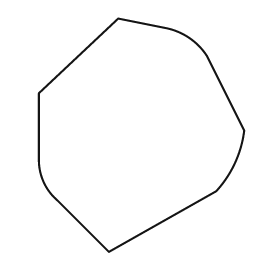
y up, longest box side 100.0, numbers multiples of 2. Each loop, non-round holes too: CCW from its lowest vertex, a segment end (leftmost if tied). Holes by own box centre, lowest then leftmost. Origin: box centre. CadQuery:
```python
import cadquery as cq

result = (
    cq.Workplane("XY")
    .moveTo(-14.0, -50.0)
    .lineTo(32.0, -24.0)
    .threePointArc((40.0, -12.0), (44.0, 2.0))
    .lineTo(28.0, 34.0)
    .threePointArc((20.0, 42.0), (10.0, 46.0))
    .lineTo(-10.0, 50.0)
    .lineTo(-44.0, 18.0)
    .lineTo(-44.0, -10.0)
    .threePointArc((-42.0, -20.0), (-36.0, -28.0))
    .close()
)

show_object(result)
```